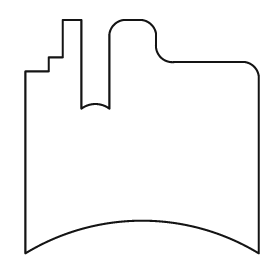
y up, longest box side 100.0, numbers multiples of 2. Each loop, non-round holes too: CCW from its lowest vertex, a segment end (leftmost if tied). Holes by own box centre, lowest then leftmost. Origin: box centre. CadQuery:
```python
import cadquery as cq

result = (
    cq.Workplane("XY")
    .moveTo(-50.0, -50.0)
    .threePointArc((0.0, -36.0), (50.0, -50.0))
    .lineTo(50.0, 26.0)
    .threePointArc((48.0, 30.0), (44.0, 32.0))
    .lineTo(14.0, 32.0)
    .threePointArc((8.0, 34.0), (6.0, 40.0))
    .lineTo(6.0, 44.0)
    .threePointArc((4.0, 48.0), (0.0, 50.0))
    .lineTo(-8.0, 50.0)
    .threePointArc((-12.0, 48.0), (-14.0, 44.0))
    .lineTo(-14.0, 12.0)
    .threePointArc((-20.0, 14.0), (-26.0, 12.0))
    .lineTo(-26.0, 50.0)
    .lineTo(-34.0, 50.0)
    .lineTo(-34.0, 34.0)
    .lineTo(-40.0, 34.0)
    .lineTo(-40.0, 28.0)
    .lineTo(-50.0, 28.0)
    .close()
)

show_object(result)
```